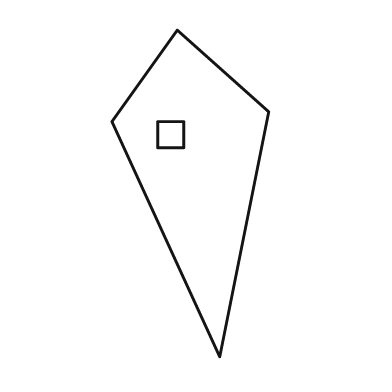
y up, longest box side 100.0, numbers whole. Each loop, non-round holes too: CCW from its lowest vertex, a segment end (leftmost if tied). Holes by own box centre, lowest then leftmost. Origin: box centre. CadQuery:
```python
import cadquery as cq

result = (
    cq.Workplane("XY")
    .moveTo(9.0, -50.0)
    .lineTo(24.0, 25.0)
    .lineTo(-4.0, 50.0)
    .lineTo(-24.0, 22.0)
    .close()
    .moveTo(-10.0, 14.0)
    .lineTo(-2.0, 14.0)
    .lineTo(-2.0, 22.0)
    .lineTo(-10.0, 22.0)
    .close()
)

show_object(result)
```